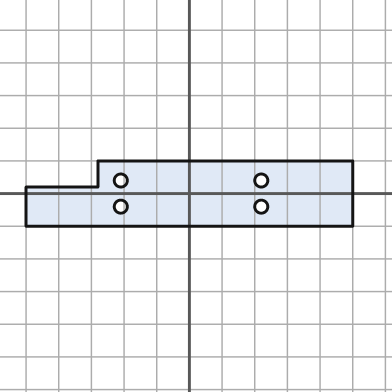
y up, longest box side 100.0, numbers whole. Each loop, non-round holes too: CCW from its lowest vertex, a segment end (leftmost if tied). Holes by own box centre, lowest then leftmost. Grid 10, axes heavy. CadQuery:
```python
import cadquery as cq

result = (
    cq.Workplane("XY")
    .moveTo(-50.0, -10.0)
    .lineTo(50.0, -10.0)
    .lineTo(50.0, 10.0)
    .lineTo(-28.0, 10.0)
    .lineTo(-28.0, 2.0)
    .lineTo(-50.0, 2.0)
    .close()
    .moveTo(-21.0, -4.0)
    .circle(2.0)
    .moveTo(22.0, -4.0)
    .circle(2.0)
    .moveTo(-21.0, 4.0)
    .circle(2.0)
    .moveTo(22.0, 4.0)
    .circle(2.0)
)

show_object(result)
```